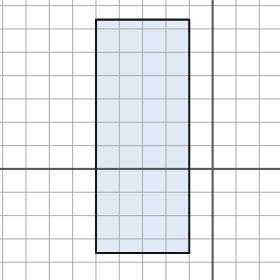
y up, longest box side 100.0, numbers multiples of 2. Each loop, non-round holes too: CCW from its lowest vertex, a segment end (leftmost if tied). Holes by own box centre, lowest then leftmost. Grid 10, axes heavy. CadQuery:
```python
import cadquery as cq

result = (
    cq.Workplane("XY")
    .moveTo(-50.0, -36.0)
    .lineTo(-10.0, -36.0)
    .lineTo(-10.0, 64.0)
    .lineTo(-50.0, 64.0)
    .close()
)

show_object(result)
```